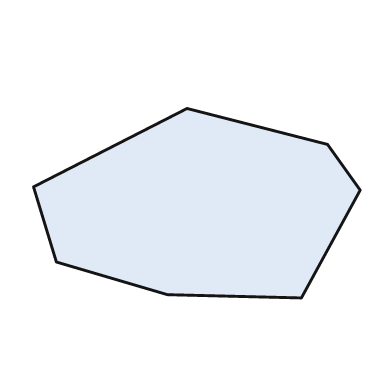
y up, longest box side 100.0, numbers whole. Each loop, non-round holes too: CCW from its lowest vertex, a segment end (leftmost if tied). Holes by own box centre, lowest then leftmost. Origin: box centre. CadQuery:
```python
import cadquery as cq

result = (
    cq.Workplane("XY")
    .moveTo(32.0, -29.0)
    .lineTo(50.0, 4.0)
    .lineTo(40.0, 18.0)
    .lineTo(-3.0, 29.0)
    .lineTo(-50.0, 5.0)
    .lineTo(-43.0, -18.0)
    .lineTo(-9.0, -28.0)
    .close()
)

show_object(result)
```